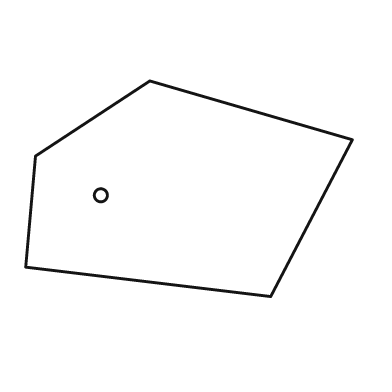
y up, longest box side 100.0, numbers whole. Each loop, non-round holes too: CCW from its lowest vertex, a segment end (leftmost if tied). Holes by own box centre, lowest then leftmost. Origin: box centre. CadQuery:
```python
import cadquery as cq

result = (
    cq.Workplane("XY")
    .moveTo(25.0, -33.0)
    .lineTo(50.0, 15.0)
    .lineTo(-12.0, 33.0)
    .lineTo(-47.0, 10.0)
    .lineTo(-50.0, -24.0)
    .close()
    .moveTo(-27.0, -2.0)
    .circle(2.0)
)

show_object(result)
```